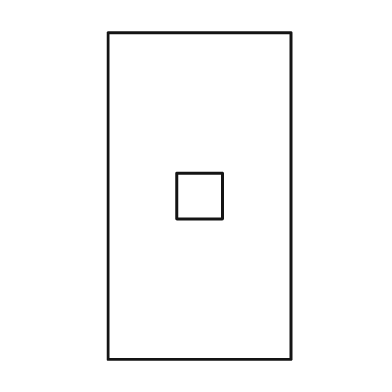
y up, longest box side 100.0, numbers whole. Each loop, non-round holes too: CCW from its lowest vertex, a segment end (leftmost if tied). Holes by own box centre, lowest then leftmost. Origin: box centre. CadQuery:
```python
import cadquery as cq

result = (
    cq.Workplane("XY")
    .moveTo(-28.0, -50.0)
    .lineTo(28.0, -50.0)
    .lineTo(28.0, 50.0)
    .lineTo(-28.0, 50.0)
    .close()
    .moveTo(-7.0, -7.0)
    .lineTo(7.0, -7.0)
    .lineTo(7.0, 7.0)
    .lineTo(-7.0, 7.0)
    .close()
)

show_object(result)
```